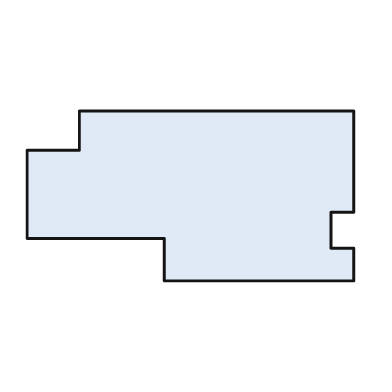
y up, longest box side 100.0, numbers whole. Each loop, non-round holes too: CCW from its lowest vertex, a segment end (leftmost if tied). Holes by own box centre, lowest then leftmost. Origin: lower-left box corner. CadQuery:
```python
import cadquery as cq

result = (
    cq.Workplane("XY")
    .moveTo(42.0, 0.0)
    .lineTo(100.0, 0.0)
    .lineTo(100.0, 10.0)
    .lineTo(93.0, 10.0)
    .lineTo(93.0, 21.0)
    .lineTo(100.0, 21.0)
    .lineTo(100.0, 52.0)
    .lineTo(16.0, 52.0)
    .lineTo(16.0, 40.0)
    .lineTo(0.0, 40.0)
    .lineTo(0.0, 13.0)
    .lineTo(42.0, 13.0)
    .close()
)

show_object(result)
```